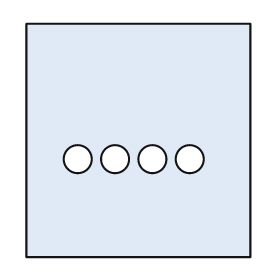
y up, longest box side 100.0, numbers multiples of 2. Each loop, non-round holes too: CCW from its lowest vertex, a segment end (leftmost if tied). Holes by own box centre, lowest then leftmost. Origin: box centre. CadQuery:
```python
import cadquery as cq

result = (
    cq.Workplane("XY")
    .moveTo(-48.0, -50.0)
    .lineTo(48.0, -50.0)
    .lineTo(48.0, 50.0)
    .lineTo(-48.0, 50.0)
    .close()
    .moveTo(-26.0, -8.0)
    .circle(6.0)
    .moveTo(-10.0, -8.0)
    .circle(6.0)
    .moveTo(6.0, -8.0)
    .circle(6.0)
    .moveTo(22.0, -8.0)
    .circle(6.0)
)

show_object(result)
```